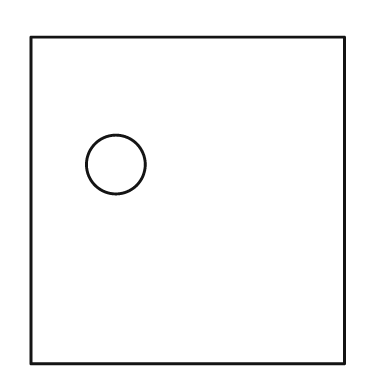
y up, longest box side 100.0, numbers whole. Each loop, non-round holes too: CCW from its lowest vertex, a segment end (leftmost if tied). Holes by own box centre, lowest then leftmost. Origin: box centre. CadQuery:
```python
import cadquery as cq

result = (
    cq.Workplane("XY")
    .moveTo(-48.0, -50.0)
    .lineTo(48.0, -50.0)
    .lineTo(48.0, 50.0)
    .lineTo(-48.0, 50.0)
    .close()
    .moveTo(-22.0, 11.0)
    .circle(9.0)
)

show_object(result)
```